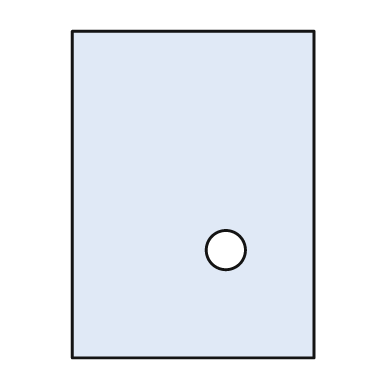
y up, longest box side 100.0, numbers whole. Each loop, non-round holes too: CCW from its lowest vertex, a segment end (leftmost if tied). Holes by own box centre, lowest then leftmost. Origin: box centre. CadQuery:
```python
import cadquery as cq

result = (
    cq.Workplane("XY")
    .moveTo(-37.0, -50.0)
    .lineTo(37.0, -50.0)
    .lineTo(37.0, 50.0)
    .lineTo(-37.0, 50.0)
    .close()
    .moveTo(10.0, -17.0)
    .circle(6.0)
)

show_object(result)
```